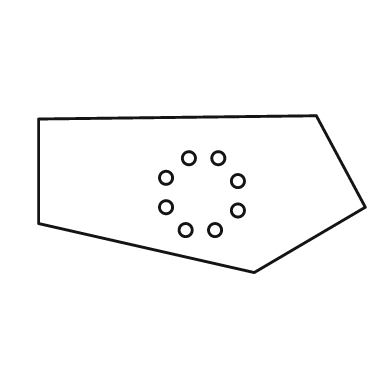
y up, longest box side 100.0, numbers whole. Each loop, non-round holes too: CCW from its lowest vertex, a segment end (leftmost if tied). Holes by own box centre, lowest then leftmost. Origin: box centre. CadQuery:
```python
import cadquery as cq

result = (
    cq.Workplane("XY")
    .moveTo(16.0, -24.0)
    .lineTo(50.0, -4.0)
    .lineTo(35.0, 24.0)
    .lineTo(-50.0, 23.0)
    .lineTo(-50.0, -9.0)
    .close()
    .moveTo(-5.0, -11.0)
    .circle(2.0)
    .moveTo(4.0, -11.0)
    .circle(2.0)
    .moveTo(11.0, -5.0)
    .circle(2.0)
    .moveTo(-11.0, -4.0)
    .circle(2.0)
    .moveTo(11.0, 4.0)
    .circle(2.0)
    .moveTo(-11.0, 5.0)
    .circle(2.0)
    .moveTo(-4.0, 11.0)
    .circle(2.0)
    .moveTo(5.0, 11.0)
    .circle(2.0)
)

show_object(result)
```